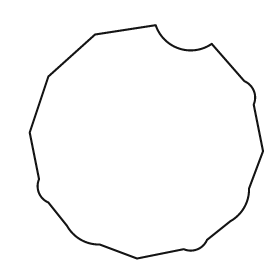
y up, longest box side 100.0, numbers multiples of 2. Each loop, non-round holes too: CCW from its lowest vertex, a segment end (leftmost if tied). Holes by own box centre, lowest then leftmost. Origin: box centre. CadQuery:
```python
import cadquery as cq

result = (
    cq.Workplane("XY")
    .moveTo(-4.0, -50.0)
    .lineTo(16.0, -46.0)
    .threePointArc((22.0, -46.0), (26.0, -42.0))
    .lineTo(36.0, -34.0)
    .threePointArc((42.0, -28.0), (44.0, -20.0))
    .lineTo(50.0, -4.0)
    .lineTo(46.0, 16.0)
    .threePointArc((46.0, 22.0), (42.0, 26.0))
    .lineTo(28.0, 42.0)
    .threePointArc((14.0, 40.0), (4.0, 50.0))
    .lineTo(-22.0, 46.0)
    .lineTo(-42.0, 28.0)
    .lineTo(-50.0, 4.0)
    .lineTo(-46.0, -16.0)
    .threePointArc((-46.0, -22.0), (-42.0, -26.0))
    .lineTo(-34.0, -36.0)
    .threePointArc((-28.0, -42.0), (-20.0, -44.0))
    .close()
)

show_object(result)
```